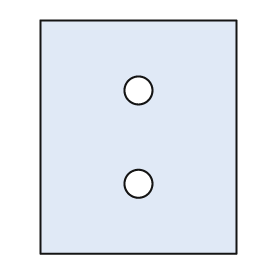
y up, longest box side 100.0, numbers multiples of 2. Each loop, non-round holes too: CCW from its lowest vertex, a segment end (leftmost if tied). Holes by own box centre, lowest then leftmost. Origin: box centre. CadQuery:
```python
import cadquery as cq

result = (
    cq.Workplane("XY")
    .moveTo(-42.0, -50.0)
    .lineTo(42.0, -50.0)
    .lineTo(42.0, 50.0)
    .lineTo(-42.0, 50.0)
    .close()
    .moveTo(0.0, -20.0)
    .circle(6.0)
    .moveTo(0.0, 20.0)
    .circle(6.0)
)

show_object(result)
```